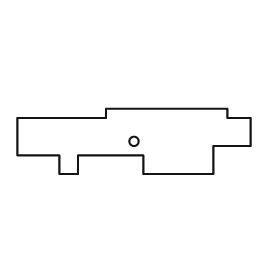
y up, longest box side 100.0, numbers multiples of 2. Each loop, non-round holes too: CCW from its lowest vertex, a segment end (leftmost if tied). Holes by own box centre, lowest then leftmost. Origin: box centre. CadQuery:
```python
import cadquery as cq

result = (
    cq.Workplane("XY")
    .moveTo(-32.0, -14.0)
    .lineTo(-24.0, -14.0)
    .lineTo(-24.0, -6.0)
    .lineTo(4.0, -6.0)
    .lineTo(4.0, -14.0)
    .lineTo(34.0, -14.0)
    .lineTo(34.0, -2.0)
    .lineTo(50.0, -2.0)
    .lineTo(50.0, 10.0)
    .lineTo(40.0, 10.0)
    .lineTo(40.0, 14.0)
    .lineTo(-12.0, 14.0)
    .lineTo(-12.0, 10.0)
    .lineTo(-50.0, 10.0)
    .lineTo(-50.0, -6.0)
    .lineTo(-32.0, -6.0)
    .close()
    .moveTo(0.0, 0.0)
    .circle(2.0)
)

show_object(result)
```